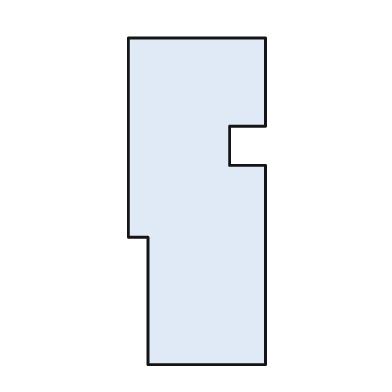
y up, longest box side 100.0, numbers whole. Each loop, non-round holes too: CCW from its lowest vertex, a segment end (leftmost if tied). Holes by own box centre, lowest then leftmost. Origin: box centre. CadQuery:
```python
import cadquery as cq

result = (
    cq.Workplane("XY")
    .moveTo(-15.0, -50.0)
    .lineTo(21.0, -50.0)
    .lineTo(21.0, 11.0)
    .lineTo(10.0, 11.0)
    .lineTo(10.0, 23.0)
    .lineTo(21.0, 23.0)
    .lineTo(21.0, 50.0)
    .lineTo(-21.0, 50.0)
    .lineTo(-21.0, -11.0)
    .lineTo(-15.0, -11.0)
    .close()
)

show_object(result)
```